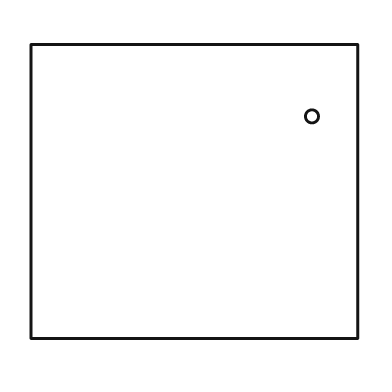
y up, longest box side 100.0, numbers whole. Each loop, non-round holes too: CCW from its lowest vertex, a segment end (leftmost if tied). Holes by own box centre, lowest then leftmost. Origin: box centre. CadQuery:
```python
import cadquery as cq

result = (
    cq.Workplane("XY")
    .moveTo(-50.0, -45.0)
    .lineTo(50.0, -45.0)
    .lineTo(50.0, 45.0)
    .lineTo(-50.0, 45.0)
    .close()
    .moveTo(36.0, 23.0)
    .circle(2.0)
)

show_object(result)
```